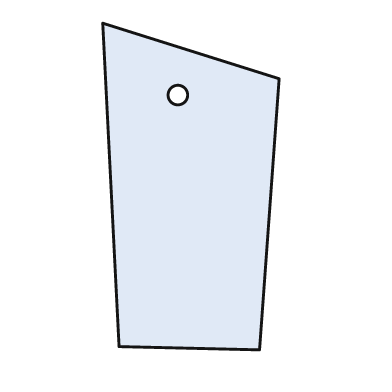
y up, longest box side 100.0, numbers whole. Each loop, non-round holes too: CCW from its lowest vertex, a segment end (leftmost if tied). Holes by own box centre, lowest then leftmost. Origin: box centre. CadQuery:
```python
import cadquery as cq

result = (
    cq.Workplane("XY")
    .moveTo(21.0, -50.0)
    .lineTo(27.0, 33.0)
    .lineTo(-27.0, 50.0)
    .lineTo(-22.0, -49.0)
    .close()
    .moveTo(-4.0, 28.0)
    .circle(3.0)
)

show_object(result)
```